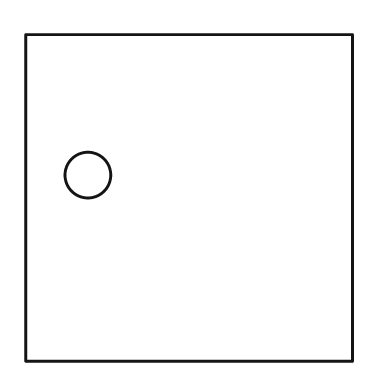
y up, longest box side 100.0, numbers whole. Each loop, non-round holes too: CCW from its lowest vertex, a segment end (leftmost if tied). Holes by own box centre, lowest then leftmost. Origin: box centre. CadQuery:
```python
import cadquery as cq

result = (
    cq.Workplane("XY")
    .moveTo(-50.0, -50.0)
    .lineTo(50.0, -50.0)
    .lineTo(50.0, 50.0)
    .lineTo(-50.0, 50.0)
    .close()
    .moveTo(-31.0, 7.0)
    .circle(7.0)
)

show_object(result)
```